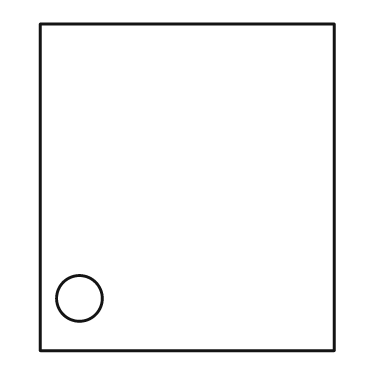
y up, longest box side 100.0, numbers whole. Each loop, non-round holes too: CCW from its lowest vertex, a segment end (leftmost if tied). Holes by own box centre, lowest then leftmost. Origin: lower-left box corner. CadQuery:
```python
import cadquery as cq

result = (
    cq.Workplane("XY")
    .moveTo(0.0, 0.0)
    .lineTo(90.0, 0.0)
    .lineTo(90.0, 100.0)
    .lineTo(0.0, 100.0)
    .close()
    .moveTo(12.0, 16.0)
    .circle(7.0)
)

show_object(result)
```